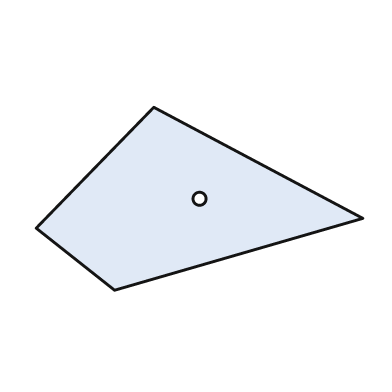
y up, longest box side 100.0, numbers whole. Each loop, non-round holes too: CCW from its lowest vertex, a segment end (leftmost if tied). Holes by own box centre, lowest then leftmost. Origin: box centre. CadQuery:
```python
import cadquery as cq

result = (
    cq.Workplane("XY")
    .moveTo(-26.0, -28.0)
    .lineTo(50.0, -6.0)
    .lineTo(-14.0, 28.0)
    .lineTo(-50.0, -9.0)
    .close()
    .moveTo(0.0, 0.0)
    .circle(2.0)
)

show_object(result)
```